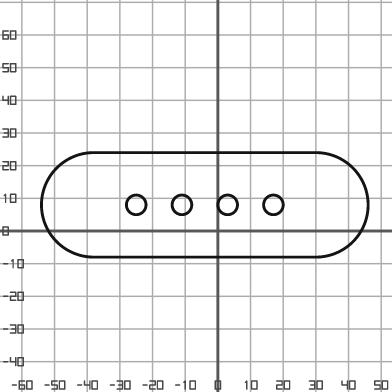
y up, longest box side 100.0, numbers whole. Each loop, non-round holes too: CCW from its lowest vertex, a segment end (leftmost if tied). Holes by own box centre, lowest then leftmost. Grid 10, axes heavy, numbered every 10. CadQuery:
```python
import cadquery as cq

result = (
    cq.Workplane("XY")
    .moveTo(-38.0, -8.0)
    .lineTo(30.0, -8.0)
    .threePointArc((46.0, 8.0), (30.0, 24.0))
    .lineTo(-38.0, 24.0)
    .threePointArc((-54.0, 8.0), (-38.0, -8.0))
    .close()
    .moveTo(-25.0, 8.0)
    .circle(3.0)
    .moveTo(-11.0, 8.0)
    .circle(3.0)
    .moveTo(3.0, 8.0)
    .circle(3.0)
    .moveTo(17.0, 8.0)
    .circle(3.0)
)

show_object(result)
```